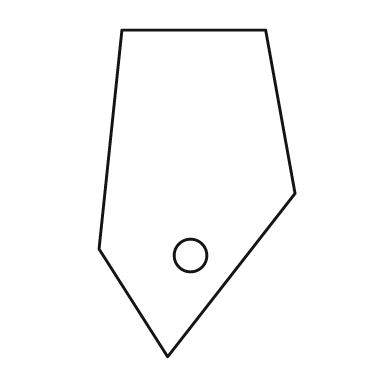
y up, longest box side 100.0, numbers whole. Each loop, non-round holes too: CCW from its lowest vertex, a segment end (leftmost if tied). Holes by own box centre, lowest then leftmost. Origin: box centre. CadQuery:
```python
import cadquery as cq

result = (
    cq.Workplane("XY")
    .moveTo(-9.0, -50.0)
    .lineTo(30.0, 0.0)
    .lineTo(21.0, 50.0)
    .lineTo(-23.0, 50.0)
    .lineTo(-30.0, -17.0)
    .close()
    .moveTo(-2.0, -19.0)
    .circle(5.0)
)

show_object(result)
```